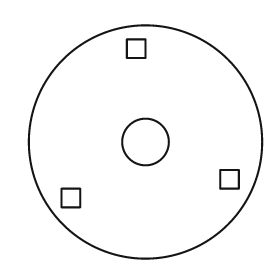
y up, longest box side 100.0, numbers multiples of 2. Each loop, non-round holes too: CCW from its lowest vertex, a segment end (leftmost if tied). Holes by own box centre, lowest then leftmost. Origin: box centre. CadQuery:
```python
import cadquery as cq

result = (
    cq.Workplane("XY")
    .moveTo(0.0, 0.0)
    .circle(50.0)
    .moveTo(-36.0, -28.0)
    .lineTo(-28.0, -28.0)
    .lineTo(-28.0, -20.0)
    .lineTo(-36.0, -20.0)
    .close()
    .moveTo(32.0, -20.0)
    .lineTo(40.0, -20.0)
    .lineTo(40.0, -12.0)
    .lineTo(32.0, -12.0)
    .close()
    .moveTo(0.0, 0.0)
    .circle(10.0)
    .moveTo(-8.0, 36.0)
    .lineTo(0.0, 36.0)
    .lineTo(0.0, 44.0)
    .lineTo(-8.0, 44.0)
    .close()
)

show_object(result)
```